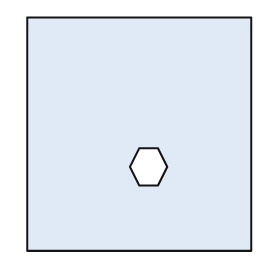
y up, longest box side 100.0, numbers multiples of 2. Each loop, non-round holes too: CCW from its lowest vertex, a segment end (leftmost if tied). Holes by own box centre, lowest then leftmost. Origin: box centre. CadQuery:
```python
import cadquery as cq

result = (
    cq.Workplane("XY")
    .moveTo(-48.0, -50.0)
    .lineTo(48.0, -50.0)
    .lineTo(48.0, 50.0)
    .lineTo(-48.0, 50.0)
    .close()
    .moveTo(0.0, -22.0)
    .lineTo(8.0, -22.0)
    .lineTo(12.0, -14.0)
    .lineTo(8.0, -6.0)
    .lineTo(0.0, -6.0)
    .lineTo(-4.0, -14.0)
    .close()
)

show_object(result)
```